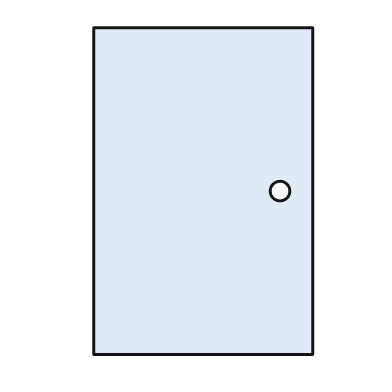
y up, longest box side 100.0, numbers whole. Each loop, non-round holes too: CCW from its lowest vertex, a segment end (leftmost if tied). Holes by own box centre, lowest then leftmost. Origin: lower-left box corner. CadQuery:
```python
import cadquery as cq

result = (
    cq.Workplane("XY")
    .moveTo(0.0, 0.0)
    .lineTo(67.0, 0.0)
    .lineTo(67.0, 100.0)
    .lineTo(0.0, 100.0)
    .close()
    .moveTo(57.0, 50.0)
    .circle(3.0)
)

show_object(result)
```